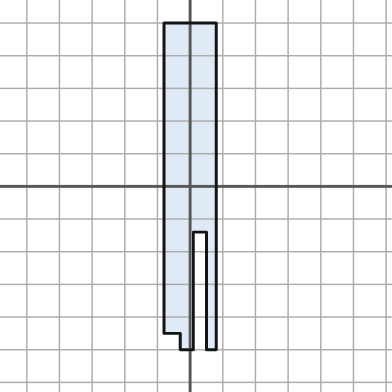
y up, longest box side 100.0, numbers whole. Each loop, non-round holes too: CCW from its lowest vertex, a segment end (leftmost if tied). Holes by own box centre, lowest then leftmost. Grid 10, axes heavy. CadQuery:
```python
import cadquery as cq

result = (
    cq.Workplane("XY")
    .moveTo(-3.0, -50.0)
    .lineTo(1.0, -50.0)
    .lineTo(1.0, -14.0)
    .lineTo(5.0, -14.0)
    .lineTo(5.0, -50.0)
    .lineTo(8.0, -50.0)
    .lineTo(8.0, 50.0)
    .lineTo(-8.0, 50.0)
    .lineTo(-8.0, -45.0)
    .lineTo(-3.0, -45.0)
    .close()
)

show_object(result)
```